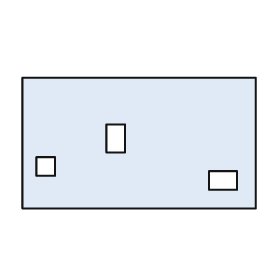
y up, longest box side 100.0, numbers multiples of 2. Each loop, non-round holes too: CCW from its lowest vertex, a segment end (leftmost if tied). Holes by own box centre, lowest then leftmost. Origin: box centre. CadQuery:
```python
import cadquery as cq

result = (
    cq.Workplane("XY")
    .moveTo(-50.0, -28.0)
    .lineTo(50.0, -28.0)
    .lineTo(50.0, 28.0)
    .lineTo(-50.0, 28.0)
    .close()
    .moveTo(30.0, -20.0)
    .lineTo(42.0, -20.0)
    .lineTo(42.0, -12.0)
    .lineTo(30.0, -12.0)
    .close()
    .moveTo(-44.0, -14.0)
    .lineTo(-36.0, -14.0)
    .lineTo(-36.0, -6.0)
    .lineTo(-44.0, -6.0)
    .close()
    .moveTo(-14.0, -4.0)
    .lineTo(-6.0, -4.0)
    .lineTo(-6.0, 8.0)
    .lineTo(-14.0, 8.0)
    .close()
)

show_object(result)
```